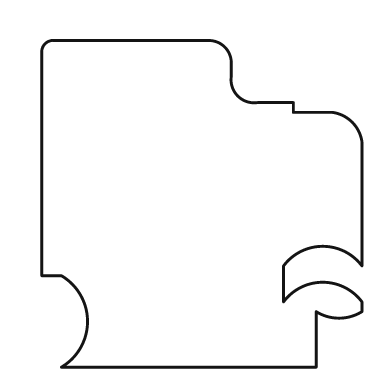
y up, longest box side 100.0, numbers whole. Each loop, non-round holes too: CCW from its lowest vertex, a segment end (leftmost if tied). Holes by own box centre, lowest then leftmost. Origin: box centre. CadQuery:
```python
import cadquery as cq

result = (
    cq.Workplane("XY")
    .moveTo(-43.0, -50.0)
    .lineTo(35.0, -50.0)
    .lineTo(35.0, -33.0)
    .threePointArc((42.0, -35.0), (49.0, -33.0))
    .lineTo(49.0, -30.0)
    .threePointArc((37.0, -24.0), (25.0, -30.0))
    .lineTo(25.0, -19.0)
    .threePointArc((37.0, -13.0), (49.0, -19.0))
    .lineTo(49.0, 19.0)
    .threePointArc((46.0, 25.0), (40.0, 28.0))
    .lineTo(28.0, 28.0)
    .lineTo(28.0, 31.0)
    .lineTo(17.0, 31.0)
    .threePointArc((11.0, 33.0), (9.0, 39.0))
    .lineTo(9.0, 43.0)
    .threePointArc((7.0, 48.0), (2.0, 50.0))
    .lineTo(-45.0, 50.0)
    .threePointArc((-48.0, 49.0), (-49.0, 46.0))
    .lineTo(-49.0, -22.0)
    .lineTo(-43.0, -22.0)
    .threePointArc((-35.0, -36.0), (-43.0, -50.0))
    .close()
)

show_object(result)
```